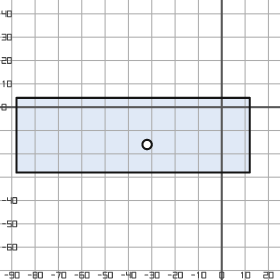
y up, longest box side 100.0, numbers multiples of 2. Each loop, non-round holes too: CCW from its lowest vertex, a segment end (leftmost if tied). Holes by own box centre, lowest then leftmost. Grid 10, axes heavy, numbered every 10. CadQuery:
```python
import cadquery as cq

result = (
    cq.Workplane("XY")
    .moveTo(-88.0, -28.0)
    .lineTo(12.0, -28.0)
    .lineTo(12.0, 4.0)
    .lineTo(-88.0, 4.0)
    .close()
    .moveTo(-32.0, -16.0)
    .circle(2.0)
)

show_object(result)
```